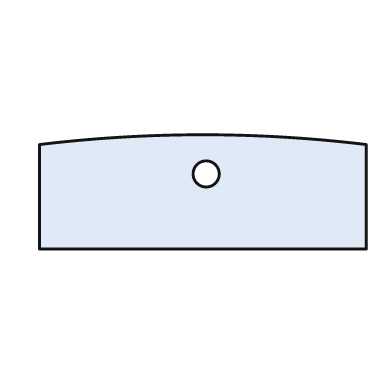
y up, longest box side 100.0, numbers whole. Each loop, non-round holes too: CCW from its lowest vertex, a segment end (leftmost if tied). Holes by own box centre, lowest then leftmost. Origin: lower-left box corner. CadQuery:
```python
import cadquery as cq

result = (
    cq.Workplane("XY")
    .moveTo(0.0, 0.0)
    .lineTo(100.0, 0.0)
    .lineTo(100.0, 32.0)
    .threePointArc((50.0, 35.0), (0.0, 32.0))
    .close()
    .moveTo(51.0, 23.0)
    .circle(4.0)
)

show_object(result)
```